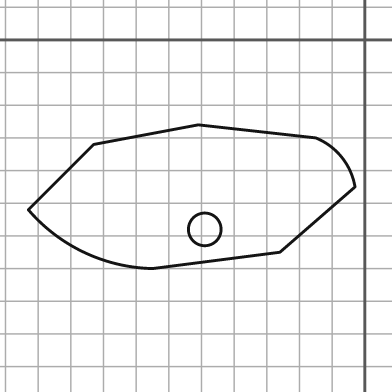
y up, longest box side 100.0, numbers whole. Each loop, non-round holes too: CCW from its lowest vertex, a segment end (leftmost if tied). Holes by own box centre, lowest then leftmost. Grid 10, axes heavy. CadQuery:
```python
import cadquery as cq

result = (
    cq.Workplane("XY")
    .moveTo(-65.0, -70.0)
    .lineTo(-26.0, -65.0)
    .lineTo(-3.0, -45.0)
    .threePointArc((-7.0, -36.0), (-15.0, -30.0))
    .lineTo(-51.0, -26.0)
    .lineTo(-83.0, -32.0)
    .lineTo(-103.0, -52.0)
    .threePointArc((-86.0, -65.0), (-65.0, -70.0))
    .close()
    .moveTo(-49.0, -58.0)
    .circle(5.0)
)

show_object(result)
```